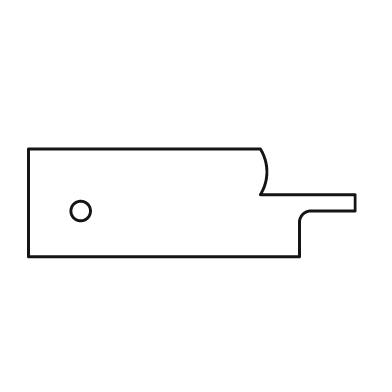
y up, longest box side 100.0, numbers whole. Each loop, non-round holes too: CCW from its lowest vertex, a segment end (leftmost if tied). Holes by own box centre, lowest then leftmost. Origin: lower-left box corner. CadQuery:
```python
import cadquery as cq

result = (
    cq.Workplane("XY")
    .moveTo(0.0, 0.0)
    .lineTo(83.0, 0.0)
    .lineTo(83.0, 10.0)
    .threePointArc((84.0, 13.0), (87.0, 14.0))
    .lineTo(100.0, 14.0)
    .lineTo(100.0, 19.0)
    .lineTo(71.0, 19.0)
    .threePointArc((73.0, 26.0), (71.0, 33.0))
    .lineTo(0.0, 33.0)
    .close()
    .moveTo(16.0, 14.0)
    .circle(3.0)
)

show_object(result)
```